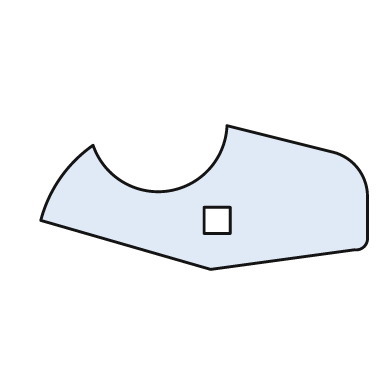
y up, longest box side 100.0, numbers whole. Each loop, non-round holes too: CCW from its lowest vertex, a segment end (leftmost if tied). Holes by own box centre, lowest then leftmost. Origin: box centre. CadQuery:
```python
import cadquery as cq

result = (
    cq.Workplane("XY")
    .moveTo(2.0, -22.0)
    .lineTo(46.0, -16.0)
    .threePointArc((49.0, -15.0), (50.0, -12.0))
    .lineTo(50.0, 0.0)
    .threePointArc((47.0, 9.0), (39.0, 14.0))
    .lineTo(7.0, 22.0)
    .threePointArc((-11.0, 2.0), (-34.0, 16.0))
    .threePointArc((-44.0, 6.0), (-50.0, -7.0))
    .close()
    .moveTo(0.0, -11.0)
    .lineTo(8.0, -11.0)
    .lineTo(8.0, -3.0)
    .lineTo(0.0, -3.0)
    .close()
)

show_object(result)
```